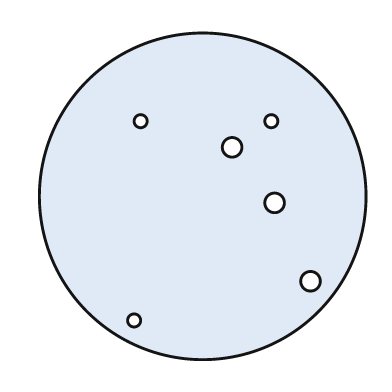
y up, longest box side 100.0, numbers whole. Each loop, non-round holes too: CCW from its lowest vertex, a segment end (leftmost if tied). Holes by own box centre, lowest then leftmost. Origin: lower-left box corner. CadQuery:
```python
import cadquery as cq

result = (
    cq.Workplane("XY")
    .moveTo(50.0, 50.0)
    .circle(50.0)
    .moveTo(29.0, 12.0)
    .circle(2.0)
    .moveTo(83.0, 24.0)
    .circle(3.0)
    .moveTo(72.0, 48.0)
    .circle(3.0)
    .moveTo(59.0, 65.0)
    .circle(3.0)
    .moveTo(31.0, 73.0)
    .circle(2.0)
    .moveTo(71.0, 73.0)
    .circle(2.0)
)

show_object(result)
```